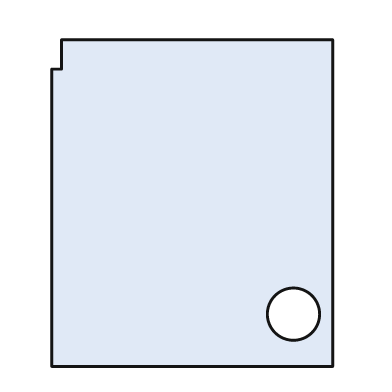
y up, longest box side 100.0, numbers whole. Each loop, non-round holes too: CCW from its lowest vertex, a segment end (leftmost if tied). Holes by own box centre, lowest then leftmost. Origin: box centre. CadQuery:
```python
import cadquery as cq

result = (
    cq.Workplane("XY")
    .moveTo(-43.0, -50.0)
    .lineTo(43.0, -50.0)
    .lineTo(43.0, 50.0)
    .lineTo(-40.0, 50.0)
    .lineTo(-40.0, 41.0)
    .lineTo(-43.0, 41.0)
    .close()
    .moveTo(31.0, -34.0)
    .circle(8.0)
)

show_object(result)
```